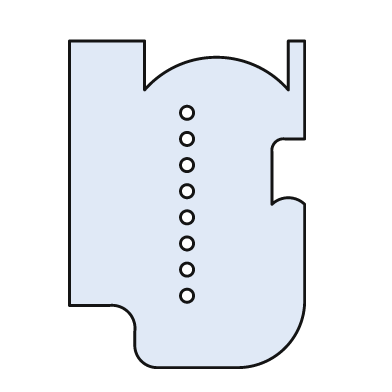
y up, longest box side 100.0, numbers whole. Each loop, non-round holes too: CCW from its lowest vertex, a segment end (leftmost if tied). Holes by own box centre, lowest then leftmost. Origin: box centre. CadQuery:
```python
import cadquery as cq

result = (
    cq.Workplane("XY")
    .moveTo(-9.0, -50.0)
    .lineTo(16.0, -50.0)
    .threePointArc((30.0, -44.0), (36.0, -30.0))
    .lineTo(36.0, 0.0)
    .threePointArc((31.0, 2.0), (26.0, 0.0))
    .lineTo(26.0, 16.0)
    .threePointArc((27.0, 19.0), (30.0, 20.0))
    .lineTo(36.0, 20.0)
    .lineTo(36.0, 50.0)
    .lineTo(31.0, 50.0)
    .lineTo(31.0, 35.0)
    .threePointArc((9.0, 45.0), (-13.0, 35.0))
    .lineTo(-13.0, 50.0)
    .lineTo(-36.0, 50.0)
    .lineTo(-36.0, -31.0)
    .lineTo(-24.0, -31.0)
    .threePointArc((-18.0, -33.0), (-16.0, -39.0))
    .lineTo(-16.0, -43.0)
    .threePointArc((-14.0, -48.0), (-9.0, -50.0))
    .close()
    .moveTo(0.0, -28.0)
    .circle(2.0)
    .moveTo(0.0, -20.0)
    .circle(2.0)
    .moveTo(0.0, -12.0)
    .circle(2.0)
    .moveTo(0.0, -4.0)
    .circle(2.0)
    .moveTo(0.0, 4.0)
    .circle(2.0)
    .moveTo(0.0, 12.0)
    .circle(2.0)
    .moveTo(0.0, 20.0)
    .circle(2.0)
    .moveTo(0.0, 28.0)
    .circle(2.0)
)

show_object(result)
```